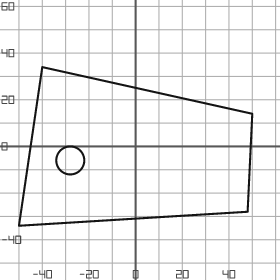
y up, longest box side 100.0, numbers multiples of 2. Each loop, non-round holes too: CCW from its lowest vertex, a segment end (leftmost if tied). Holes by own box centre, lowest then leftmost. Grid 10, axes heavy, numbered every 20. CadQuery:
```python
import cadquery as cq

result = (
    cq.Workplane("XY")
    .moveTo(-50.0, -34.0)
    .lineTo(48.0, -28.0)
    .lineTo(50.0, 14.0)
    .lineTo(-40.0, 34.0)
    .close()
    .moveTo(-28.0, -6.0)
    .circle(6.0)
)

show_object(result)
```